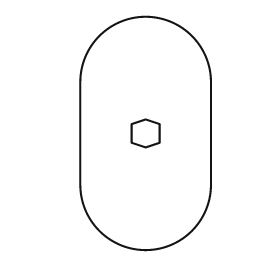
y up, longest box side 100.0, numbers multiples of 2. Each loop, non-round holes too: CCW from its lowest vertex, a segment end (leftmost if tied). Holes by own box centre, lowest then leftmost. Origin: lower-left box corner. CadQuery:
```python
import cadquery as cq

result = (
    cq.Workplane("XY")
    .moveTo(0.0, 28.0)
    .threePointArc((28.0, 0.0), (56.0, 28.0))
    .lineTo(56.0, 72.0)
    .threePointArc((28.0, 100.0), (0.0, 72.0))
    .close()
    .moveTo(28.0, 44.0)
    .lineTo(34.0, 46.0)
    .lineTo(34.0, 54.0)
    .lineTo(28.0, 56.0)
    .lineTo(22.0, 54.0)
    .lineTo(22.0, 46.0)
    .close()
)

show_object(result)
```